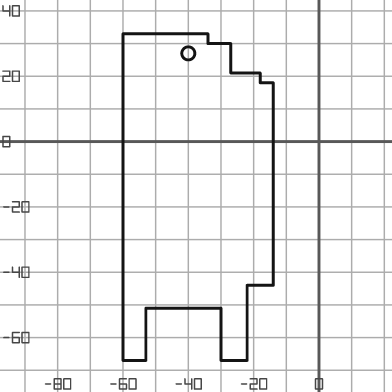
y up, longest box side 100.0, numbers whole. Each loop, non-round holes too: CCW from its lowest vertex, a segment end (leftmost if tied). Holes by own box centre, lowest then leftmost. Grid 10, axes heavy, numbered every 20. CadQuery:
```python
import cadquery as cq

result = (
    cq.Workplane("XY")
    .moveTo(-60.0, -67.0)
    .lineTo(-53.0, -67.0)
    .lineTo(-53.0, -51.0)
    .lineTo(-30.0, -51.0)
    .lineTo(-30.0, -67.0)
    .lineTo(-22.0, -67.0)
    .lineTo(-22.0, -44.0)
    .lineTo(-14.0, -44.0)
    .lineTo(-14.0, 18.0)
    .lineTo(-18.0, 18.0)
    .lineTo(-18.0, 21.0)
    .lineTo(-27.0, 21.0)
    .lineTo(-27.0, 30.0)
    .lineTo(-34.0, 30.0)
    .lineTo(-34.0, 33.0)
    .lineTo(-60.0, 33.0)
    .close()
    .moveTo(-40.0, 27.0)
    .circle(2.0)
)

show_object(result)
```